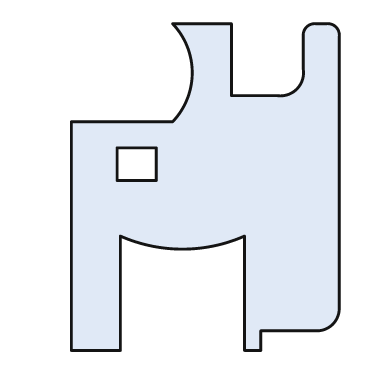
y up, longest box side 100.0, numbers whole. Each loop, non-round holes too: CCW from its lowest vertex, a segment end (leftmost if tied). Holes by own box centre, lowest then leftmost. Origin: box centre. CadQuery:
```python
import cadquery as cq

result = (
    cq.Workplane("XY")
    .moveTo(-41.0, -50.0)
    .lineTo(-26.0, -50.0)
    .lineTo(-26.0, -15.0)
    .threePointArc((-7.0, -19.0), (12.0, -15.0))
    .lineTo(12.0, -50.0)
    .lineTo(17.0, -50.0)
    .lineTo(17.0, -44.0)
    .lineTo(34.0, -44.0)
    .threePointArc((39.0, -42.0), (41.0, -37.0))
    .lineTo(41.0, 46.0)
    .threePointArc((40.0, 49.0), (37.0, 50.0))
    .lineTo(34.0, 50.0)
    .threePointArc((31.0, 49.0), (30.0, 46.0))
    .lineTo(30.0, 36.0)
    .threePointArc((28.0, 30.0), (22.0, 28.0))
    .lineTo(8.0, 28.0)
    .lineTo(8.0, 50.0)
    .lineTo(-10.0, 50.0)
    .threePointArc((-4.0, 35.0), (-10.0, 20.0))
    .lineTo(-41.0, 20.0)
    .close()
    .moveTo(-27.0, 2.0)
    .lineTo(-15.0, 2.0)
    .lineTo(-15.0, 12.0)
    .lineTo(-27.0, 12.0)
    .close()
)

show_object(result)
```